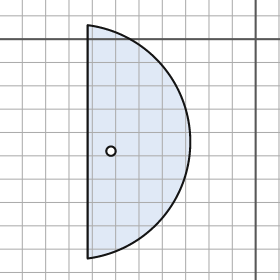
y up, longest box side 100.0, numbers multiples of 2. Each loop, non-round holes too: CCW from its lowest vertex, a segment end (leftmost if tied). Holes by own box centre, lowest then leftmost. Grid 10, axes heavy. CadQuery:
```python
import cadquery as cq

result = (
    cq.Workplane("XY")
    .moveTo(-72.0, -94.0)
    .threePointArc((-28.0, -44.0), (-72.0, 6.0))
    .close()
    .moveTo(-62.0, -48.0)
    .circle(2.0)
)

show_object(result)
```